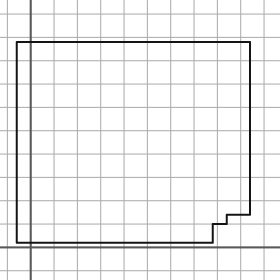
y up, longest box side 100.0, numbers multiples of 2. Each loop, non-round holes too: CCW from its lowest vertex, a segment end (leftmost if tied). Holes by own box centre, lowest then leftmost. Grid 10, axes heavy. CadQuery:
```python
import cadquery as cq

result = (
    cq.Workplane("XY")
    .moveTo(-6.0, 2.0)
    .lineTo(78.0, 2.0)
    .lineTo(78.0, 10.0)
    .lineTo(84.0, 10.0)
    .lineTo(84.0, 14.0)
    .lineTo(94.0, 14.0)
    .lineTo(94.0, 88.0)
    .lineTo(-6.0, 88.0)
    .close()
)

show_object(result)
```